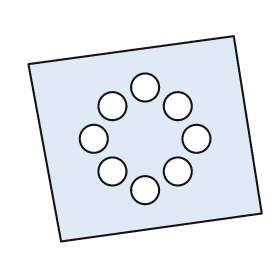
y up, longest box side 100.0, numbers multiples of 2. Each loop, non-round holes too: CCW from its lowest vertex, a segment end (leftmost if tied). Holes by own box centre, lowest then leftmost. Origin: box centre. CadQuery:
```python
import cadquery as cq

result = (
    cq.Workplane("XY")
    .moveTo(-36.0, -44.0)
    .lineTo(50.0, -32.0)
    .lineTo(38.0, 44.0)
    .lineTo(-50.0, 32.0)
    .close()
    .moveTo(0.0, -22.0)
    .circle(6.0)
    .moveTo(-14.0, -14.0)
    .circle(6.0)
    .moveTo(14.0, -14.0)
    .circle(6.0)
    .moveTo(-22.0, 0.0)
    .circle(6.0)
    .moveTo(22.0, 0.0)
    .circle(6.0)
    .moveTo(-14.0, 14.0)
    .circle(6.0)
    .moveTo(14.0, 14.0)
    .circle(6.0)
    .moveTo(0.0, 22.0)
    .circle(6.0)
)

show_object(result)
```